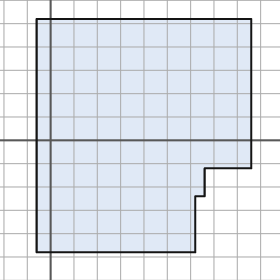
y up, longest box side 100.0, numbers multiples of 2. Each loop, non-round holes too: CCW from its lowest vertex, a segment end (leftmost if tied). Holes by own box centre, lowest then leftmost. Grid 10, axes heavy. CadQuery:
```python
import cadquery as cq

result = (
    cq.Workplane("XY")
    .moveTo(-6.0, -48.0)
    .lineTo(62.0, -48.0)
    .lineTo(62.0, -24.0)
    .lineTo(66.0, -24.0)
    .lineTo(66.0, -12.0)
    .lineTo(86.0, -12.0)
    .lineTo(86.0, 52.0)
    .lineTo(-6.0, 52.0)
    .close()
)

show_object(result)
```